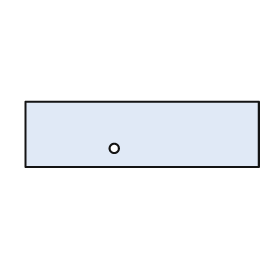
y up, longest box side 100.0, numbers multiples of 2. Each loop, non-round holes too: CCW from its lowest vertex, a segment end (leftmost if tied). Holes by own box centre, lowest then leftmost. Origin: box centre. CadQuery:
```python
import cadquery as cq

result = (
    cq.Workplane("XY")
    .moveTo(-50.0, -14.0)
    .lineTo(50.0, -14.0)
    .lineTo(50.0, 14.0)
    .lineTo(-50.0, 14.0)
    .close()
    .moveTo(-12.0, -6.0)
    .circle(2.0)
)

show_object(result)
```